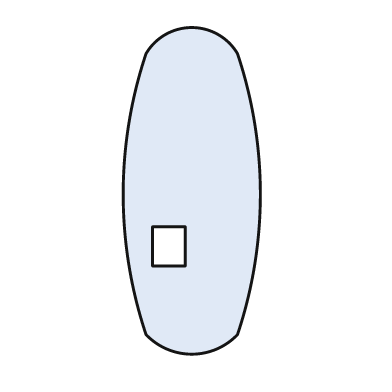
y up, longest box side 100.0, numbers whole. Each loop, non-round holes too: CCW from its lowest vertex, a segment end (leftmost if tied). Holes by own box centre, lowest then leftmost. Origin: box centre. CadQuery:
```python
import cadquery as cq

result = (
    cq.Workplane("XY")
    .moveTo(-14.0, -44.0)
    .threePointArc((0.0, -50.0), (14.0, -44.0))
    .threePointArc((21.0, -1.0), (14.0, 42.0))
    .threePointArc((0.0, 50.0), (-14.0, 42.0))
    .threePointArc((-21.0, -1.0), (-14.0, -44.0))
    .close()
    .moveTo(-12.0, -23.0)
    .lineTo(-2.0, -23.0)
    .lineTo(-2.0, -11.0)
    .lineTo(-12.0, -11.0)
    .close()
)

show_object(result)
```